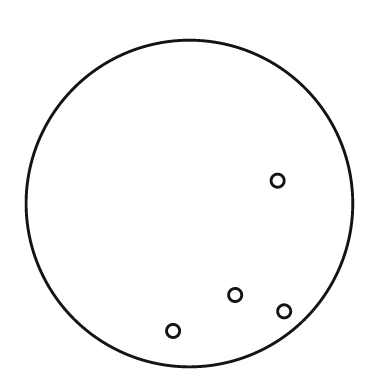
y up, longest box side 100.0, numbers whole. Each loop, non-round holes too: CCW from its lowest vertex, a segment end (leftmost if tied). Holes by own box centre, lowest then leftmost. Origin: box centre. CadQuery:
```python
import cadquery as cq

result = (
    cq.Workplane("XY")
    .moveTo(0.0, 0.0)
    .circle(50.0)
    .moveTo(-5.0, -39.0)
    .circle(2.0)
    .moveTo(29.0, -33.0)
    .circle(2.0)
    .moveTo(14.0, -28.0)
    .circle(2.0)
    .moveTo(27.0, 7.0)
    .circle(2.0)
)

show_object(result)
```